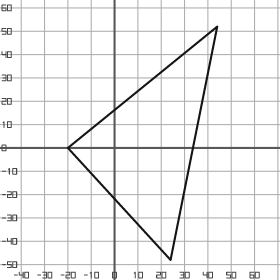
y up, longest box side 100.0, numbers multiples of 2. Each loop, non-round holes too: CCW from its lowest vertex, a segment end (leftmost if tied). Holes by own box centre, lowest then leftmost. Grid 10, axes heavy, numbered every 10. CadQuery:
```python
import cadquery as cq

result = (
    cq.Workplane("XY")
    .moveTo(24.0, -48.0)
    .lineTo(44.0, 52.0)
    .lineTo(-20.0, 0.0)
    .close()
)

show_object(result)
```